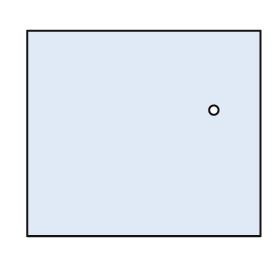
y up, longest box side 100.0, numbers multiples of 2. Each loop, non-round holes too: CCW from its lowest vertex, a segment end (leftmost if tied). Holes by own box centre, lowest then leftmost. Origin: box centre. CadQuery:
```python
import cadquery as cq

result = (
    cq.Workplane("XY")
    .moveTo(-50.0, -44.0)
    .lineTo(50.0, -44.0)
    .lineTo(50.0, 44.0)
    .lineTo(-50.0, 44.0)
    .close()
    .moveTo(30.0, 10.0)
    .circle(2.0)
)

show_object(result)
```